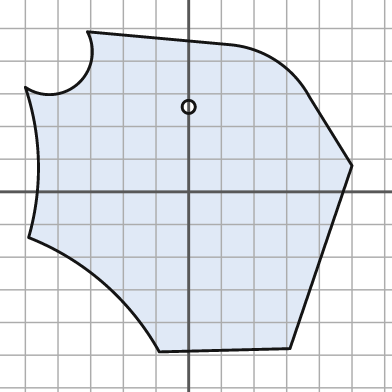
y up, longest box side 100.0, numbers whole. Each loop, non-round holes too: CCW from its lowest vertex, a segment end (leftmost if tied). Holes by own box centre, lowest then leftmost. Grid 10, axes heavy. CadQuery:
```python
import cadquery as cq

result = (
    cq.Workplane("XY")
    .moveTo(-9.0, -49.0)
    .lineTo(31.0, -48.0)
    .lineTo(50.0, 8.0)
    .lineTo(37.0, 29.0)
    .threePointArc((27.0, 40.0), (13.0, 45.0))
    .lineTo(-31.0, 49.0)
    .threePointArc((-34.0, 33.0), (-50.0, 32.0))
    .threePointArc((-46.0, 9.0), (-49.0, -14.0))
    .threePointArc((-26.0, -28.0), (-9.0, -49.0))
    .close()
    .moveTo(0.0, 26.0)
    .circle(2.0)
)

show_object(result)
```